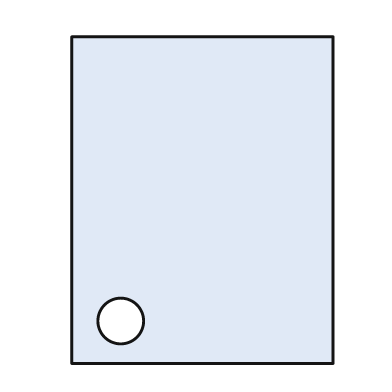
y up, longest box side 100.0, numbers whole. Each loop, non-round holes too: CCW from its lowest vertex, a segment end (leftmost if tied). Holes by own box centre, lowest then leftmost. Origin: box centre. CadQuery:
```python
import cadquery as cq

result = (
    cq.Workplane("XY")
    .moveTo(-40.0, -50.0)
    .lineTo(40.0, -50.0)
    .lineTo(40.0, 50.0)
    .lineTo(-40.0, 50.0)
    .close()
    .moveTo(-25.0, -37.0)
    .circle(7.0)
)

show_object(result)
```